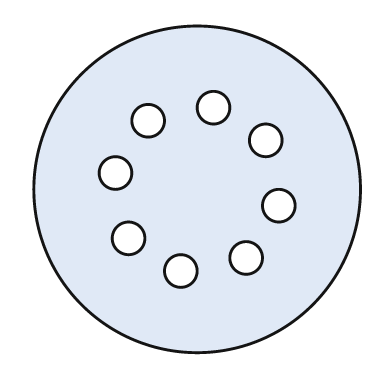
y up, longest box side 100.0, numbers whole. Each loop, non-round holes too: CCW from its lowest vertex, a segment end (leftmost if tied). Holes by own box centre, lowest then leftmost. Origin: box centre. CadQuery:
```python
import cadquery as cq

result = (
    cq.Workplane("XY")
    .moveTo(0.0, 0.0)
    .circle(50.0)
    .moveTo(-5.0, -25.0)
    .circle(5.0)
    .moveTo(15.0, -21.0)
    .circle(5.0)
    .moveTo(-21.0, -15.0)
    .circle(5.0)
    .moveTo(25.0, -5.0)
    .circle(5.0)
    .moveTo(-25.0, 5.0)
    .circle(5.0)
    .moveTo(21.0, 15.0)
    .circle(5.0)
    .moveTo(-15.0, 21.0)
    .circle(5.0)
    .moveTo(5.0, 25.0)
    .circle(5.0)
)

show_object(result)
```